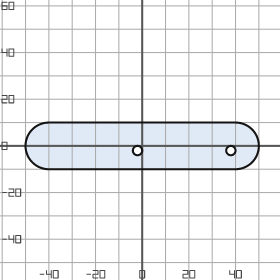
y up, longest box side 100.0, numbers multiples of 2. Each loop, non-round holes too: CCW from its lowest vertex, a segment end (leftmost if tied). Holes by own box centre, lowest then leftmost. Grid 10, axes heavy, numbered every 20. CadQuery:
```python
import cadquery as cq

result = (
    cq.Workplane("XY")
    .moveTo(-40.0, -10.0)
    .lineTo(40.0, -10.0)
    .threePointArc((50.0, 0.0), (40.0, 10.0))
    .lineTo(-40.0, 10.0)
    .threePointArc((-50.0, 0.0), (-40.0, -10.0))
    .close()
    .moveTo(-2.0, -2.0)
    .circle(2.0)
    .moveTo(38.0, -2.0)
    .circle(2.0)
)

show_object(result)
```